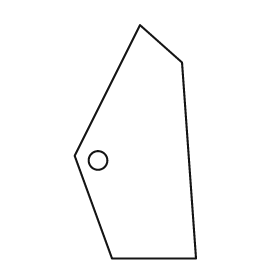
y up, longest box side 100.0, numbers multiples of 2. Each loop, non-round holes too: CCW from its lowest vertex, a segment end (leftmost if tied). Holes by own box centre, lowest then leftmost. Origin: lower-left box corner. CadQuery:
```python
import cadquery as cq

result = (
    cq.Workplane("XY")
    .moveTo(16.0, 0.0)
    .lineTo(52.0, 0.0)
    .lineTo(46.0, 84.0)
    .lineTo(28.0, 100.0)
    .lineTo(0.0, 44.0)
    .close()
    .moveTo(10.0, 42.0)
    .circle(4.0)
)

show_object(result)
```